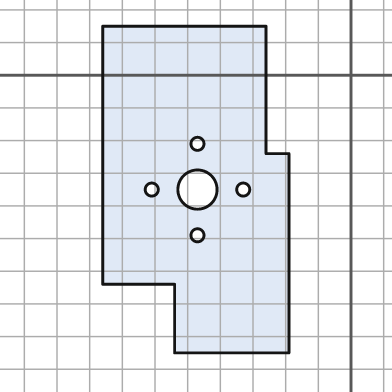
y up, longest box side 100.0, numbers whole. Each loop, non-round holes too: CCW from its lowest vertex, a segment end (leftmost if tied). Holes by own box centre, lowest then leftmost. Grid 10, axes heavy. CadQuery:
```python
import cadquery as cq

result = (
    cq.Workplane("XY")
    .moveTo(-54.0, -85.0)
    .lineTo(-19.0, -85.0)
    .lineTo(-19.0, -24.0)
    .lineTo(-26.0, -24.0)
    .lineTo(-26.0, 15.0)
    .lineTo(-76.0, 15.0)
    .lineTo(-76.0, -64.0)
    .lineTo(-54.0, -64.0)
    .close()
    .moveTo(-47.0, -49.0)
    .circle(2.0)
    .moveTo(-61.0, -35.0)
    .circle(2.0)
    .moveTo(-47.0, -35.0)
    .circle(6.0)
    .moveTo(-33.0, -35.0)
    .circle(2.0)
    .moveTo(-47.0, -21.0)
    .circle(2.0)
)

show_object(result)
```